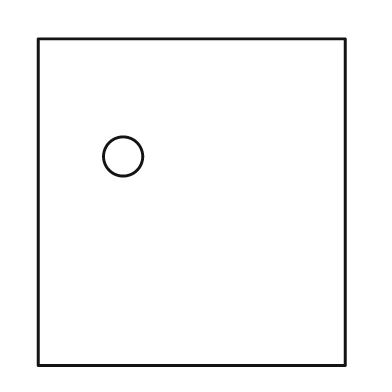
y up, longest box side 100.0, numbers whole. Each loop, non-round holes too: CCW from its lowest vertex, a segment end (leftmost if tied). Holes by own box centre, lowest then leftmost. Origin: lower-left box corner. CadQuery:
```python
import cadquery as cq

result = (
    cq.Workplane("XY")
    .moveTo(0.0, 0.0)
    .lineTo(94.0, 0.0)
    .lineTo(94.0, 100.0)
    .lineTo(0.0, 100.0)
    .close()
    .moveTo(26.0, 64.0)
    .circle(6.0)
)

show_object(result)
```